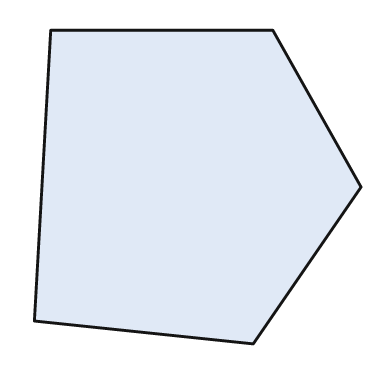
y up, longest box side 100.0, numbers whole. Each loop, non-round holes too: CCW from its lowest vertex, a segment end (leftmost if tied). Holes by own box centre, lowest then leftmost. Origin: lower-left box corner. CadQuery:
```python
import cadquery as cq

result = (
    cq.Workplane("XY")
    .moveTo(67.0, 0.0)
    .lineTo(100.0, 48.0)
    .lineTo(73.0, 96.0)
    .lineTo(5.0, 96.0)
    .lineTo(0.0, 7.0)
    .close()
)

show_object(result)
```